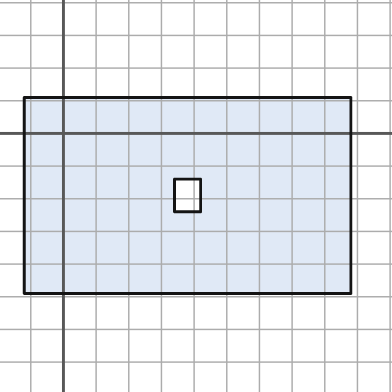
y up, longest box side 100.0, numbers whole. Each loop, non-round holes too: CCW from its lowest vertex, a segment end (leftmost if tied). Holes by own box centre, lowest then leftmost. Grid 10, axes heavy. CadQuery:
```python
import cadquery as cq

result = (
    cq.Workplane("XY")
    .moveTo(-12.0, -49.0)
    .lineTo(88.0, -49.0)
    .lineTo(88.0, 11.0)
    .lineTo(-12.0, 11.0)
    .close()
    .moveTo(34.0, -24.0)
    .lineTo(42.0, -24.0)
    .lineTo(42.0, -14.0)
    .lineTo(34.0, -14.0)
    .close()
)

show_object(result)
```